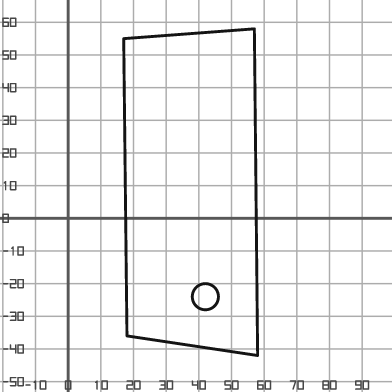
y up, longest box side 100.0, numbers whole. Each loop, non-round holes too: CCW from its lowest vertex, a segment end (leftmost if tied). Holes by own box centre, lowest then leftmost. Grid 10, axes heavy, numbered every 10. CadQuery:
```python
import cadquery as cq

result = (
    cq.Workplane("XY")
    .moveTo(58.0, -42.0)
    .lineTo(57.0, 58.0)
    .lineTo(17.0, 55.0)
    .lineTo(18.0, -36.0)
    .close()
    .moveTo(42.0, -24.0)
    .circle(4.0)
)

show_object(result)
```